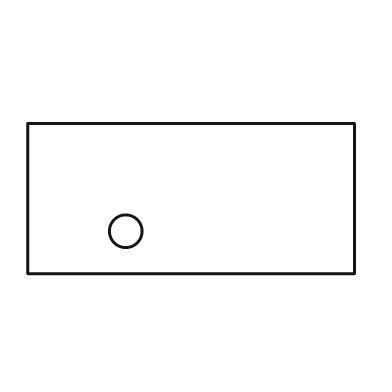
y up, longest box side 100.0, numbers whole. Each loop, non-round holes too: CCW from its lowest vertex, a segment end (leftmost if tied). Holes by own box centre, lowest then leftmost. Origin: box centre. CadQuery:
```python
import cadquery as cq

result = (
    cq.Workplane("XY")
    .moveTo(-50.0, -23.0)
    .lineTo(50.0, -23.0)
    .lineTo(50.0, 23.0)
    .lineTo(-50.0, 23.0)
    .close()
    .moveTo(-20.0, -10.0)
    .circle(5.0)
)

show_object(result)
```